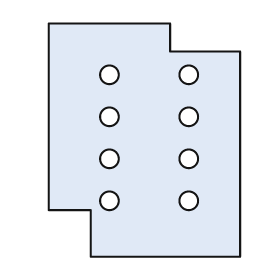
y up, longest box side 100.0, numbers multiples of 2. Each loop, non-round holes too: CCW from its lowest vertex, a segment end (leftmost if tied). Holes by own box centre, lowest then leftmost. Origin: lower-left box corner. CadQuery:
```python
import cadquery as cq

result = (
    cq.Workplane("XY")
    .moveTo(18.0, 0.0)
    .lineTo(82.0, 0.0)
    .lineTo(82.0, 88.0)
    .lineTo(52.0, 88.0)
    .lineTo(52.0, 100.0)
    .lineTo(0.0, 100.0)
    .lineTo(0.0, 20.0)
    .lineTo(18.0, 20.0)
    .close()
    .moveTo(26.0, 24.0)
    .circle(4.0)
    .moveTo(60.0, 24.0)
    .circle(4.0)
    .moveTo(26.0, 42.0)
    .circle(4.0)
    .moveTo(60.0, 42.0)
    .circle(4.0)
    .moveTo(26.0, 60.0)
    .circle(4.0)
    .moveTo(60.0, 60.0)
    .circle(4.0)
    .moveTo(26.0, 78.0)
    .circle(4.0)
    .moveTo(60.0, 78.0)
    .circle(4.0)
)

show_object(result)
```